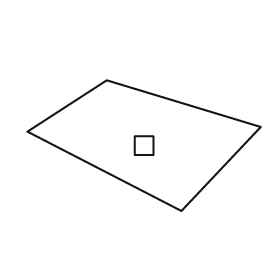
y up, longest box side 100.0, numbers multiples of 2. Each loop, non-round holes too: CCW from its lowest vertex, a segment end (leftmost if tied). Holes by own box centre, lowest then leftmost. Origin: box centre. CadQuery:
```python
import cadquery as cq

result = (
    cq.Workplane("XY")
    .moveTo(16.0, -28.0)
    .lineTo(50.0, 8.0)
    .lineTo(-16.0, 28.0)
    .lineTo(-50.0, 6.0)
    .close()
    .moveTo(-4.0, -4.0)
    .lineTo(4.0, -4.0)
    .lineTo(4.0, 4.0)
    .lineTo(-4.0, 4.0)
    .close()
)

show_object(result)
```